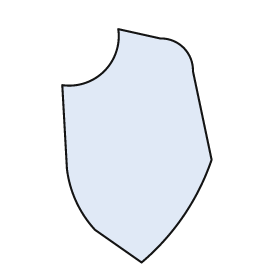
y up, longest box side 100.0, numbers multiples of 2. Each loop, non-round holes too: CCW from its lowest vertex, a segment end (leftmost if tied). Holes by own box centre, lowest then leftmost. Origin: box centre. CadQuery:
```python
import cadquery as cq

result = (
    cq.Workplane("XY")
    .moveTo(2.0, -50.0)
    .threePointArc((20.0, -30.0), (32.0, -6.0))
    .lineTo(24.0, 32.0)
    .threePointArc((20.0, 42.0), (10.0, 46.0))
    .lineTo(-8.0, 50.0)
    .threePointArc((-14.0, 32.0), (-32.0, 26.0))
    .lineTo(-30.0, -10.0)
    .threePointArc((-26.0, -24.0), (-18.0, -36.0))
    .close()
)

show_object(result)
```